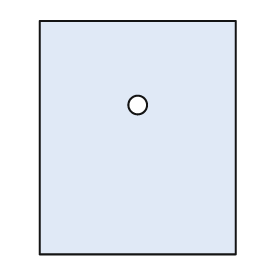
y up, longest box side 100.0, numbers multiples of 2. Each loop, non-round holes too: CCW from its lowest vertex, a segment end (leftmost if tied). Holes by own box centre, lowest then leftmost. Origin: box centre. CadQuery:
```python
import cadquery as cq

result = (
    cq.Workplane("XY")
    .moveTo(-42.0, -50.0)
    .lineTo(42.0, -50.0)
    .lineTo(42.0, 50.0)
    .lineTo(-42.0, 50.0)
    .close()
    .moveTo(0.0, 14.0)
    .circle(4.0)
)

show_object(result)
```